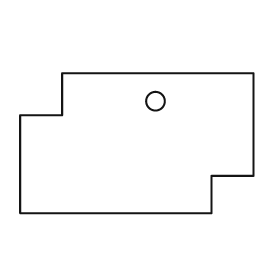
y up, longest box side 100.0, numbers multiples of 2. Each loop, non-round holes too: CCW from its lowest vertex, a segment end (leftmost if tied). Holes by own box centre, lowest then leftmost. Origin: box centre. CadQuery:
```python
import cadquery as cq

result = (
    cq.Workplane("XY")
    .moveTo(-50.0, -30.0)
    .lineTo(32.0, -30.0)
    .lineTo(32.0, -14.0)
    .lineTo(50.0, -14.0)
    .lineTo(50.0, 30.0)
    .lineTo(-32.0, 30.0)
    .lineTo(-32.0, 12.0)
    .lineTo(-50.0, 12.0)
    .close()
    .moveTo(8.0, 18.0)
    .circle(4.0)
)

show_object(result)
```